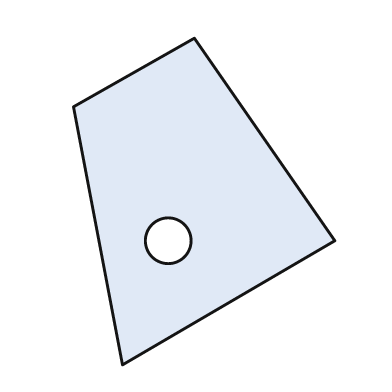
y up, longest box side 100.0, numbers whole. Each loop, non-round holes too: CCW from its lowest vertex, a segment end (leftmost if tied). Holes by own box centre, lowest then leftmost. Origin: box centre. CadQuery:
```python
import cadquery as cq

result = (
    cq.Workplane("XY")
    .moveTo(-25.0, -50.0)
    .lineTo(40.0, -12.0)
    .lineTo(-3.0, 50.0)
    .lineTo(-40.0, 29.0)
    .close()
    .moveTo(-11.0, -12.0)
    .circle(7.0)
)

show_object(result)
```